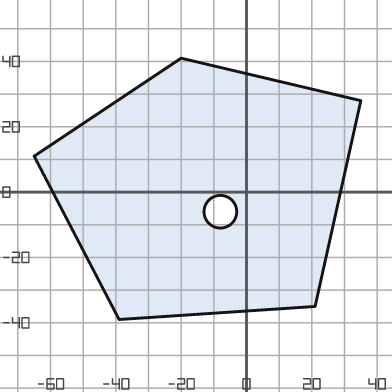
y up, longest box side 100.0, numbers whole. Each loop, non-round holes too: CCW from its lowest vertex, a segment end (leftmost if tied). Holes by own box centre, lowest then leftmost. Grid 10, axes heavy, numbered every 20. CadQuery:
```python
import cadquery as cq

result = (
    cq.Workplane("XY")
    .moveTo(-39.0, -39.0)
    .lineTo(21.0, -35.0)
    .lineTo(35.0, 28.0)
    .lineTo(-20.0, 41.0)
    .lineTo(-65.0, 11.0)
    .close()
    .moveTo(-8.0, -6.0)
    .circle(5.0)
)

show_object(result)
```